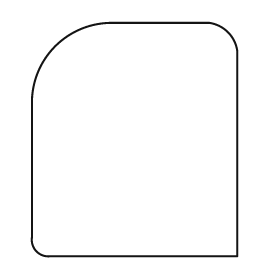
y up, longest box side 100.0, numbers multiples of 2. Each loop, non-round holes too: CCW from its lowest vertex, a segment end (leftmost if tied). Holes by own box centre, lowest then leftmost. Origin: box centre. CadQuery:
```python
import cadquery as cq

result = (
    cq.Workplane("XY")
    .moveTo(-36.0, -50.0)
    .lineTo(44.0, -50.0)
    .lineTo(44.0, 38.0)
    .threePointArc((40.0, 46.0), (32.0, 50.0))
    .lineTo(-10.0, 50.0)
    .threePointArc((-34.0, 40.0), (-44.0, 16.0))
    .lineTo(-44.0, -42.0)
    .threePointArc((-42.0, -48.0), (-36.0, -50.0))
    .close()
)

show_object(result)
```